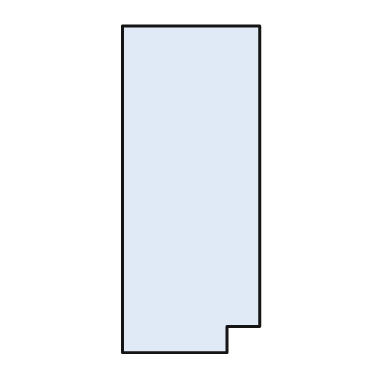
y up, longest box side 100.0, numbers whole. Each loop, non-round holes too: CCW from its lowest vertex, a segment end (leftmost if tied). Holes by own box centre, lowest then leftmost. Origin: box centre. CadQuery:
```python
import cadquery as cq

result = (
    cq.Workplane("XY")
    .moveTo(-21.0, -50.0)
    .lineTo(11.0, -50.0)
    .lineTo(11.0, -42.0)
    .lineTo(21.0, -42.0)
    .lineTo(21.0, 50.0)
    .lineTo(-21.0, 50.0)
    .close()
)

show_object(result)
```